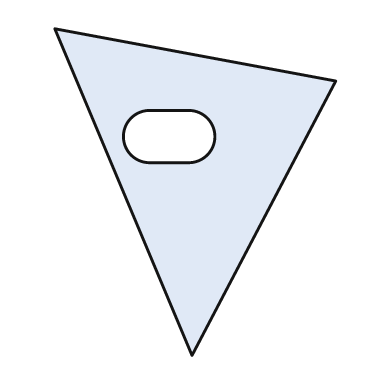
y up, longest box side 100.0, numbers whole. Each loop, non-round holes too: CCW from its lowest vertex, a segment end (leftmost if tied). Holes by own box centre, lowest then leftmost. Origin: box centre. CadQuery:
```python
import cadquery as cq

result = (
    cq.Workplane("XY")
    .moveTo(-1.0, -50.0)
    .lineTo(43.0, 34.0)
    .lineTo(-43.0, 50.0)
    .close()
    .moveTo(-14.0, 9.0)
    .lineTo(-2.0, 9.0)
    .threePointArc((6.0, 17.0), (-2.0, 25.0))
    .lineTo(-14.0, 25.0)
    .threePointArc((-22.0, 17.0), (-14.0, 9.0))
    .close()
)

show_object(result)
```